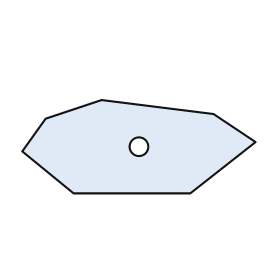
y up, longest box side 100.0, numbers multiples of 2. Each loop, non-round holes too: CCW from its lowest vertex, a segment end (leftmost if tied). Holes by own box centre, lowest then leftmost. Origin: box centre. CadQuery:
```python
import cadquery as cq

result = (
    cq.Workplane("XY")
    .moveTo(-28.0, -20.0)
    .lineTo(22.0, -20.0)
    .lineTo(50.0, 2.0)
    .lineTo(32.0, 14.0)
    .lineTo(-16.0, 20.0)
    .lineTo(-40.0, 12.0)
    .lineTo(-50.0, -2.0)
    .close()
    .moveTo(0.0, 0.0)
    .circle(4.0)
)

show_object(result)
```